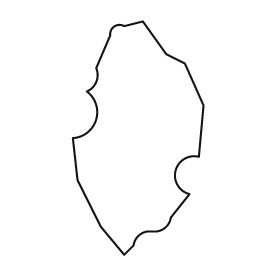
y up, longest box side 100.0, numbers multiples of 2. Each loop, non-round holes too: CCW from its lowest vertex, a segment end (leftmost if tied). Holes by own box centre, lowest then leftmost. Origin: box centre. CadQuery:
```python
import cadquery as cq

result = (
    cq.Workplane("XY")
    .moveTo(-6.0, -50.0)
    .lineTo(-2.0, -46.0)
    .threePointArc((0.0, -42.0), (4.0, -40.0))
    .lineTo(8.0, -40.0)
    .threePointArc((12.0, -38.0), (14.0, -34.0))
    .lineTo(22.0, -24.0)
    .threePointArc((16.0, -14.0), (26.0, -8.0))
    .lineTo(28.0, 14.0)
    .lineTo(20.0, 32.0)
    .lineTo(12.0, 36.0)
    .lineTo(2.0, 50.0)
    .lineTo(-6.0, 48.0)
    .threePointArc((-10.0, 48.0), (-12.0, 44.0))
    .lineTo(-18.0, 30.0)
    .threePointArc((-18.0, 24.0), (-22.0, 20.0))
    .threePointArc((-18.0, 8.0), (-28.0, 0.0))
    .lineTo(-26.0, -18.0)
    .lineTo(-16.0, -38.0)
    .close()
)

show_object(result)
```